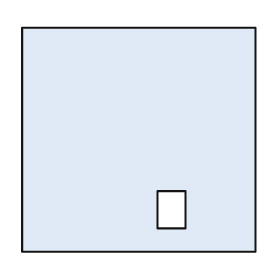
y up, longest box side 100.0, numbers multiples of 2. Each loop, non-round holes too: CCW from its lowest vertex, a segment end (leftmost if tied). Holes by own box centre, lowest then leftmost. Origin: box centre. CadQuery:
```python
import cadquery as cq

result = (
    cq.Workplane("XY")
    .moveTo(-50.0, -48.0)
    .lineTo(50.0, -48.0)
    .lineTo(50.0, 48.0)
    .lineTo(-50.0, 48.0)
    .close()
    .moveTo(8.0, -38.0)
    .lineTo(20.0, -38.0)
    .lineTo(20.0, -22.0)
    .lineTo(8.0, -22.0)
    .close()
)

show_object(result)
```